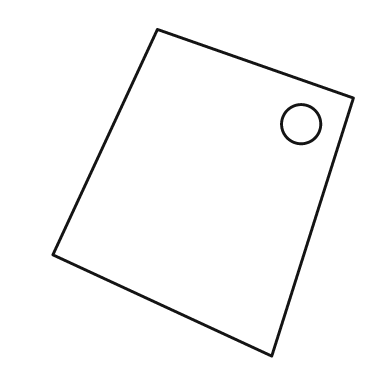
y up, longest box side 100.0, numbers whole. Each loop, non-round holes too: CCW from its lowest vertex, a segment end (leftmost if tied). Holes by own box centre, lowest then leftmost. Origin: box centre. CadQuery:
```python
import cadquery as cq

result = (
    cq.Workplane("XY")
    .moveTo(21.0, -50.0)
    .lineTo(46.0, 29.0)
    .lineTo(-14.0, 50.0)
    .lineTo(-46.0, -19.0)
    .close()
    .moveTo(30.0, 21.0)
    .circle(6.0)
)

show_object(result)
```